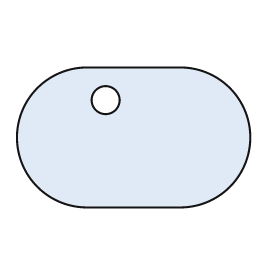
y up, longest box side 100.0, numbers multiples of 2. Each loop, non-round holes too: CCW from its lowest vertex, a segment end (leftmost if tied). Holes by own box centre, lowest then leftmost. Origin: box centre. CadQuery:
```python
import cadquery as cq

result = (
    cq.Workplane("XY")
    .moveTo(-20.0, -30.0)
    .lineTo(20.0, -30.0)
    .threePointArc((50.0, 0.0), (20.0, 30.0))
    .lineTo(-20.0, 30.0)
    .threePointArc((-50.0, 0.0), (-20.0, -30.0))
    .close()
    .moveTo(-12.0, 16.0)
    .circle(6.0)
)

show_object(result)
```